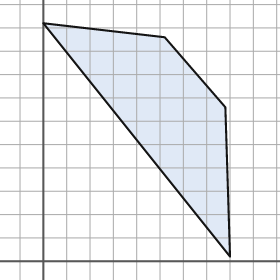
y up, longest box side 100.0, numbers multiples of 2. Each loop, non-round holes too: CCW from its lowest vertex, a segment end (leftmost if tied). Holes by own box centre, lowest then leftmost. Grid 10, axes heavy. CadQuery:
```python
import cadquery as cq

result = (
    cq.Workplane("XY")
    .moveTo(80.0, 2.0)
    .lineTo(78.0, 66.0)
    .lineTo(52.0, 96.0)
    .lineTo(0.0, 102.0)
    .close()
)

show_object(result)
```